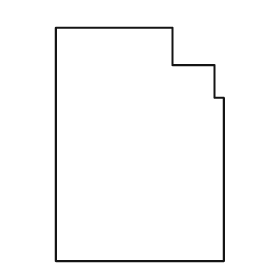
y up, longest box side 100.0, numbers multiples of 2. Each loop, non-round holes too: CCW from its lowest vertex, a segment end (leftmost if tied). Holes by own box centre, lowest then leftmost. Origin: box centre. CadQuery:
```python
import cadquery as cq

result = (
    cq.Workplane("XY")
    .moveTo(-36.0, -50.0)
    .lineTo(36.0, -50.0)
    .lineTo(36.0, 20.0)
    .lineTo(32.0, 20.0)
    .lineTo(32.0, 34.0)
    .lineTo(14.0, 34.0)
    .lineTo(14.0, 50.0)
    .lineTo(-36.0, 50.0)
    .close()
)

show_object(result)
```